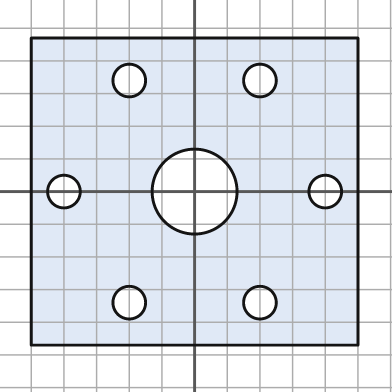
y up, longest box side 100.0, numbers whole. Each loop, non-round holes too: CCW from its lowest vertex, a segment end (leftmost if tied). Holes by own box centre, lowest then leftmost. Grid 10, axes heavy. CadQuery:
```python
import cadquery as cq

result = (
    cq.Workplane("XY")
    .moveTo(-50.0, -47.0)
    .lineTo(50.0, -47.0)
    .lineTo(50.0, 47.0)
    .lineTo(-50.0, 47.0)
    .close()
    .moveTo(-20.0, -34.0)
    .circle(5.0)
    .moveTo(20.0, -34.0)
    .circle(5.0)
    .moveTo(-40.0, 0.0)
    .circle(5.0)
    .moveTo(0.0, 0.0)
    .circle(13.0)
    .moveTo(40.0, 0.0)
    .circle(5.0)
    .moveTo(-20.0, 34.0)
    .circle(5.0)
    .moveTo(20.0, 34.0)
    .circle(5.0)
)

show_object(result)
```